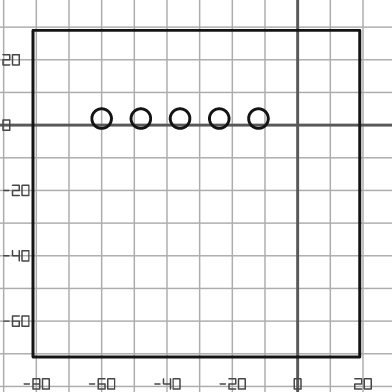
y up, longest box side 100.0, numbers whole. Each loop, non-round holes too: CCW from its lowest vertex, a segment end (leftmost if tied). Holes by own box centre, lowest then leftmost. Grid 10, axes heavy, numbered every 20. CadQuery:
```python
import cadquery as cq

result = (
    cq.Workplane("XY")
    .moveTo(-81.0, -71.0)
    .lineTo(19.0, -71.0)
    .lineTo(19.0, 29.0)
    .lineTo(-81.0, 29.0)
    .close()
    .moveTo(-60.0, 2.0)
    .circle(3.0)
    .moveTo(-48.0, 2.0)
    .circle(3.0)
    .moveTo(-36.0, 2.0)
    .circle(3.0)
    .moveTo(-24.0, 2.0)
    .circle(3.0)
    .moveTo(-12.0, 2.0)
    .circle(3.0)
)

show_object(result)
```